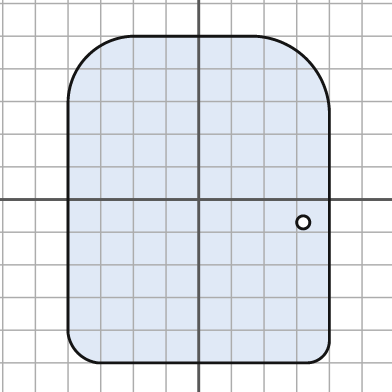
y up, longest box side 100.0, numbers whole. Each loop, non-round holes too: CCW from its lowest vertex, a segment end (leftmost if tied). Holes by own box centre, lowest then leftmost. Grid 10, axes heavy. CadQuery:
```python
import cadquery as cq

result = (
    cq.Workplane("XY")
    .moveTo(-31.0, -50.0)
    .lineTo(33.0, -50.0)
    .threePointArc((38.0, -48.0), (40.0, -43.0))
    .lineTo(40.0, 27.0)
    .threePointArc((33.0, 43.0), (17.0, 50.0))
    .lineTo(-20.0, 50.0)
    .threePointArc((-34.0, 44.0), (-40.0, 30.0))
    .lineTo(-40.0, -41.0)
    .threePointArc((-37.0, -47.0), (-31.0, -50.0))
    .close()
    .moveTo(32.0, -7.0)
    .circle(2.0)
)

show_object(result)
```